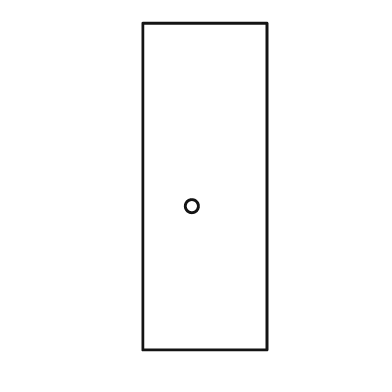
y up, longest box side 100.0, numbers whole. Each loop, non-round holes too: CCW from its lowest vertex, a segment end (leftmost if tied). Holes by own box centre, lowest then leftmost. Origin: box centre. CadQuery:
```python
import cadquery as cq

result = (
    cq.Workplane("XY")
    .moveTo(-19.0, -50.0)
    .lineTo(19.0, -50.0)
    .lineTo(19.0, 50.0)
    .lineTo(-19.0, 50.0)
    .close()
    .moveTo(-4.0, -6.0)
    .circle(2.0)
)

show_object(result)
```